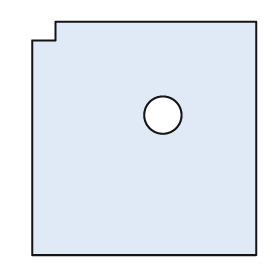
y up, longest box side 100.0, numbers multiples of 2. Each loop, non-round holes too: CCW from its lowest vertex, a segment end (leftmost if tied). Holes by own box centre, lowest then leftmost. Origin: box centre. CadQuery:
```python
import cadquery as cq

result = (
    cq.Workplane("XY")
    .moveTo(-48.0, -50.0)
    .lineTo(48.0, -50.0)
    .lineTo(48.0, 50.0)
    .lineTo(-38.0, 50.0)
    .lineTo(-38.0, 42.0)
    .lineTo(-48.0, 42.0)
    .close()
    .moveTo(8.0, 10.0)
    .circle(8.0)
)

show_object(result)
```